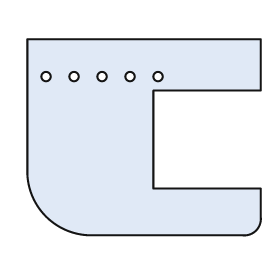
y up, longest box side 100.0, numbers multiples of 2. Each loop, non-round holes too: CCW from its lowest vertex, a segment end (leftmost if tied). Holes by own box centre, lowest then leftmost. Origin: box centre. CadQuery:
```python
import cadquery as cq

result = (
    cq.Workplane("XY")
    .moveTo(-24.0, -42.0)
    .lineTo(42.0, -42.0)
    .threePointArc((48.0, -40.0), (50.0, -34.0))
    .lineTo(50.0, -22.0)
    .lineTo(4.0, -22.0)
    .lineTo(4.0, 20.0)
    .lineTo(50.0, 20.0)
    .lineTo(50.0, 42.0)
    .lineTo(-50.0, 42.0)
    .lineTo(-50.0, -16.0)
    .threePointArc((-42.0, -34.0), (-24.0, -42.0))
    .close()
    .moveTo(-42.0, 26.0)
    .circle(2.0)
    .moveTo(-30.0, 26.0)
    .circle(2.0)
    .moveTo(-18.0, 26.0)
    .circle(2.0)
    .moveTo(-6.0, 26.0)
    .circle(2.0)
    .moveTo(6.0, 26.0)
    .circle(2.0)
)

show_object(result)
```